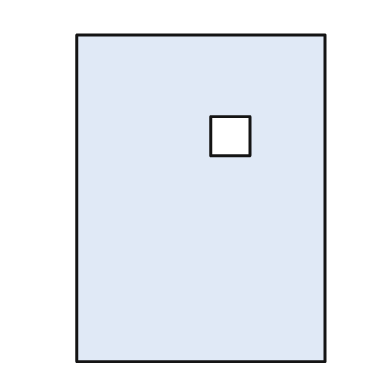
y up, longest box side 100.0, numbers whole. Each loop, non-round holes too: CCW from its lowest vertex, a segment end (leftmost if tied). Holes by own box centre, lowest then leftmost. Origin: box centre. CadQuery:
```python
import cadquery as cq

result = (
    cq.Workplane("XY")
    .moveTo(-38.0, -50.0)
    .lineTo(38.0, -50.0)
    .lineTo(38.0, 50.0)
    .lineTo(-38.0, 50.0)
    .close()
    .moveTo(3.0, 13.0)
    .lineTo(15.0, 13.0)
    .lineTo(15.0, 25.0)
    .lineTo(3.0, 25.0)
    .close()
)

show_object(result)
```